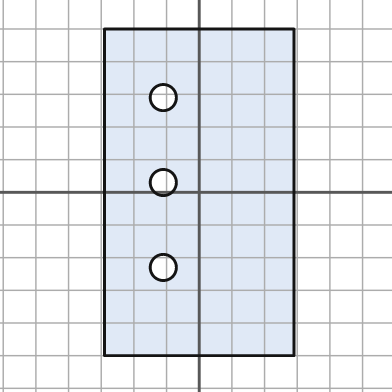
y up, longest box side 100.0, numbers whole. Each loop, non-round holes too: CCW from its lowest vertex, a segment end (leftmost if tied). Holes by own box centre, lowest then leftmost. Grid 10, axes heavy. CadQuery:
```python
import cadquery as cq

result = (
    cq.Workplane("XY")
    .moveTo(-29.0, -50.0)
    .lineTo(29.0, -50.0)
    .lineTo(29.0, 50.0)
    .lineTo(-29.0, 50.0)
    .close()
    .moveTo(-11.0, -23.0)
    .circle(4.0)
    .moveTo(-11.0, 3.0)
    .circle(4.0)
    .moveTo(-11.0, 29.0)
    .circle(4.0)
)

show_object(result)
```